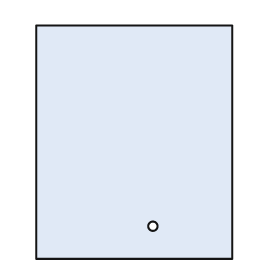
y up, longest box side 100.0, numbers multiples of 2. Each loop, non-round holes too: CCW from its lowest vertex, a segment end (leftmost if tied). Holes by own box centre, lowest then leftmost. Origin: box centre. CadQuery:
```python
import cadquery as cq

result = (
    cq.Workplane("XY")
    .moveTo(-42.0, -50.0)
    .lineTo(42.0, -50.0)
    .lineTo(42.0, 50.0)
    .lineTo(-42.0, 50.0)
    .close()
    .moveTo(8.0, -36.0)
    .circle(2.0)
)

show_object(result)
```